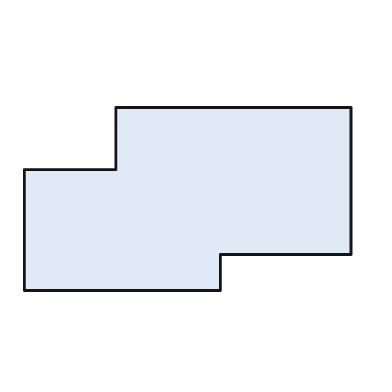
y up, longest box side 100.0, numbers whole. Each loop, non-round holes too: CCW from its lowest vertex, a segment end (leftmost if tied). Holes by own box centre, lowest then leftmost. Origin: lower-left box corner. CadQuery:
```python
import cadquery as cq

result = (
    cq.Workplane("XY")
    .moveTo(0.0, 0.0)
    .lineTo(60.0, 0.0)
    .lineTo(60.0, 11.0)
    .lineTo(100.0, 11.0)
    .lineTo(100.0, 56.0)
    .lineTo(28.0, 56.0)
    .lineTo(28.0, 37.0)
    .lineTo(0.0, 37.0)
    .close()
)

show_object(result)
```